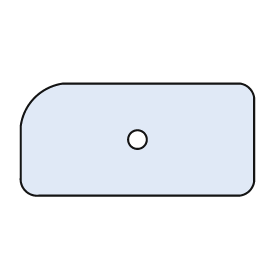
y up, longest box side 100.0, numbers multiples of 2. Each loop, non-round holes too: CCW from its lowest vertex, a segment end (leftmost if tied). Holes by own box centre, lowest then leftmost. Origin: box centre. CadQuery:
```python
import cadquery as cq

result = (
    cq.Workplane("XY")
    .moveTo(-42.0, -24.0)
    .lineTo(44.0, -24.0)
    .threePointArc((48.0, -22.0), (50.0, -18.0))
    .lineTo(50.0, 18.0)
    .threePointArc((48.0, 22.0), (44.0, 24.0))
    .lineTo(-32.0, 24.0)
    .threePointArc((-44.0, 18.0), (-50.0, 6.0))
    .lineTo(-50.0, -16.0)
    .threePointArc((-48.0, -22.0), (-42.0, -24.0))
    .close()
    .moveTo(0.0, 0.0)
    .circle(4.0)
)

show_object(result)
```